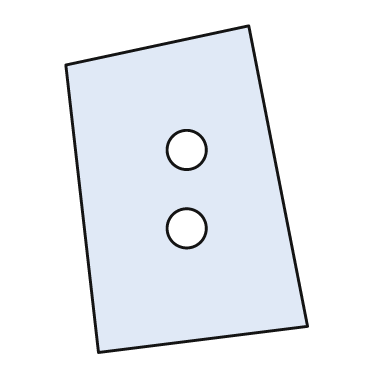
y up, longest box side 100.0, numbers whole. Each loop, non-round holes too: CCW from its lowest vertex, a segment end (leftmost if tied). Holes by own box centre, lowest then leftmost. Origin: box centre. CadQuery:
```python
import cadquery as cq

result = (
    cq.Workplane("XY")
    .moveTo(-27.0, -50.0)
    .lineTo(37.0, -42.0)
    .lineTo(19.0, 50.0)
    .lineTo(-37.0, 38.0)
    .close()
    .moveTo(0.0, -12.0)
    .circle(6.0)
    .moveTo(0.0, 12.0)
    .circle(6.0)
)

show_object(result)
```